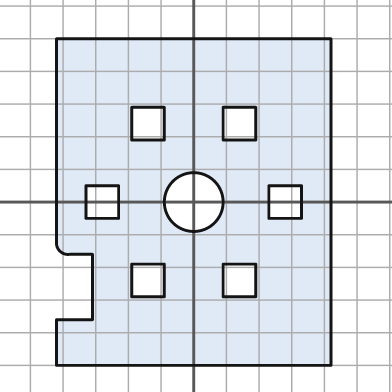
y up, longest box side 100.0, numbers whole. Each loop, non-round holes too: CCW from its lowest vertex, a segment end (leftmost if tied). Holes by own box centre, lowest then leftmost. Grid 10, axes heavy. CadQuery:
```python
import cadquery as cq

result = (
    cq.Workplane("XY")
    .moveTo(-42.0, -50.0)
    .lineTo(42.0, -50.0)
    .lineTo(42.0, 50.0)
    .lineTo(-42.0, 50.0)
    .lineTo(-42.0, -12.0)
    .threePointArc((-41.0, -15.0), (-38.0, -16.0))
    .lineTo(-31.0, -16.0)
    .lineTo(-31.0, -36.0)
    .lineTo(-42.0, -36.0)
    .close()
    .moveTo(-19.0, -29.0)
    .lineTo(-9.0, -29.0)
    .lineTo(-9.0, -19.0)
    .lineTo(-19.0, -19.0)
    .close()
    .moveTo(9.0, -29.0)
    .lineTo(19.0, -29.0)
    .lineTo(19.0, -19.0)
    .lineTo(9.0, -19.0)
    .close()
    .moveTo(-33.0, -5.0)
    .lineTo(-23.0, -5.0)
    .lineTo(-23.0, 5.0)
    .lineTo(-33.0, 5.0)
    .close()
    .moveTo(0.0, 0.0)
    .circle(9.0)
    .moveTo(23.0, -5.0)
    .lineTo(33.0, -5.0)
    .lineTo(33.0, 5.0)
    .lineTo(23.0, 5.0)
    .close()
    .moveTo(-19.0, 19.0)
    .lineTo(-9.0, 19.0)
    .lineTo(-9.0, 29.0)
    .lineTo(-19.0, 29.0)
    .close()
    .moveTo(9.0, 19.0)
    .lineTo(19.0, 19.0)
    .lineTo(19.0, 29.0)
    .lineTo(9.0, 29.0)
    .close()
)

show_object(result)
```